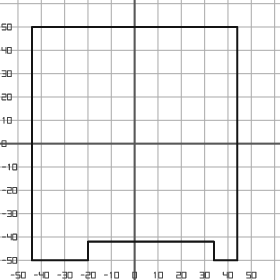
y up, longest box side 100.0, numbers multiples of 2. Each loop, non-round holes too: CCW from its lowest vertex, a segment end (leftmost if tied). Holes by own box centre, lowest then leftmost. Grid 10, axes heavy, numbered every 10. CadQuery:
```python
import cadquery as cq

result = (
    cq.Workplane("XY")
    .moveTo(-44.0, -50.0)
    .lineTo(-20.0, -50.0)
    .lineTo(-20.0, -42.0)
    .lineTo(34.0, -42.0)
    .lineTo(34.0, -50.0)
    .lineTo(44.0, -50.0)
    .lineTo(44.0, 50.0)
    .lineTo(-44.0, 50.0)
    .close()
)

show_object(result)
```